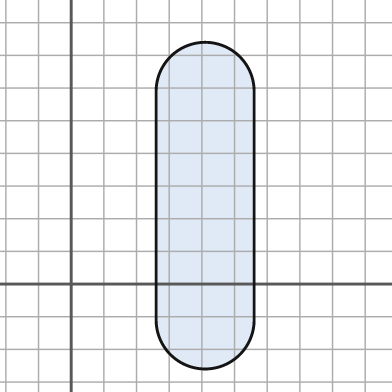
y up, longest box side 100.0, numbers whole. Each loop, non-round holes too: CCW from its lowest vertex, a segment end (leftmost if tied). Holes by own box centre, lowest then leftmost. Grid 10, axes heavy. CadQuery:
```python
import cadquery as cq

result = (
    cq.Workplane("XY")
    .moveTo(26.0, -11.0)
    .threePointArc((41.0, -26.0), (56.0, -11.0))
    .lineTo(56.0, 59.0)
    .threePointArc((41.0, 74.0), (26.0, 59.0))
    .close()
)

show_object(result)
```